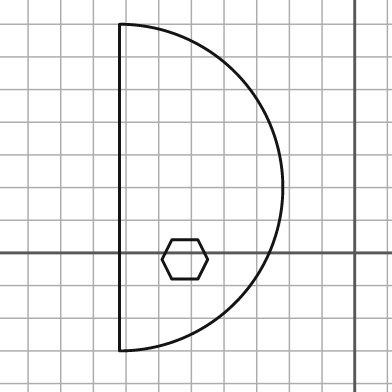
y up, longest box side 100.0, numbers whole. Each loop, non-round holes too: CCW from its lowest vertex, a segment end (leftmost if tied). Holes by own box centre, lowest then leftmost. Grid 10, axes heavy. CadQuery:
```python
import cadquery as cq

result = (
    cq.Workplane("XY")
    .moveTo(-72.0, -30.0)
    .threePointArc((-22.0, 20.0), (-72.0, 70.0))
    .close()
    .moveTo(-56.0, -8.0)
    .lineTo(-48.0, -8.0)
    .lineTo(-45.0, -2.0)
    .lineTo(-48.0, 4.0)
    .lineTo(-56.0, 4.0)
    .lineTo(-59.0, -2.0)
    .close()
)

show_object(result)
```